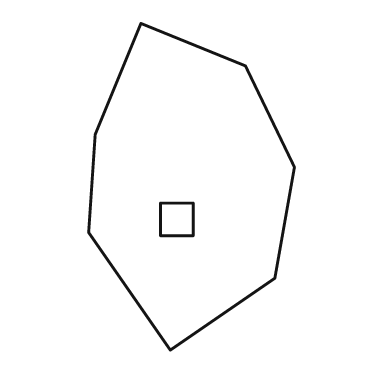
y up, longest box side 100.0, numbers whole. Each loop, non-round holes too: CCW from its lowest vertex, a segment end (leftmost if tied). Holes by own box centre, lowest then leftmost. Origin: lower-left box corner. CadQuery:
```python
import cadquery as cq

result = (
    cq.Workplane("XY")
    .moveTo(25.0, 0.0)
    .lineTo(57.0, 22.0)
    .lineTo(63.0, 56.0)
    .lineTo(48.0, 87.0)
    .lineTo(16.0, 100.0)
    .lineTo(2.0, 66.0)
    .lineTo(0.0, 36.0)
    .close()
    .moveTo(22.0, 35.0)
    .lineTo(32.0, 35.0)
    .lineTo(32.0, 45.0)
    .lineTo(22.0, 45.0)
    .close()
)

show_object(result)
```